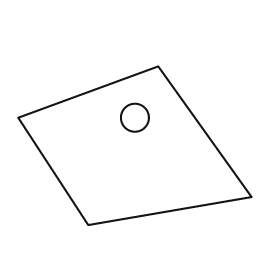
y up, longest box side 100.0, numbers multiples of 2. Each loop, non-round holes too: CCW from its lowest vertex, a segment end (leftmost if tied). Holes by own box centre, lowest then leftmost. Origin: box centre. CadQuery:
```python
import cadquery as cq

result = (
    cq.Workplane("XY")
    .moveTo(-20.0, -34.0)
    .lineTo(50.0, -22.0)
    .lineTo(10.0, 34.0)
    .lineTo(-50.0, 12.0)
    .close()
    .moveTo(0.0, 12.0)
    .circle(6.0)
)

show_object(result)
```